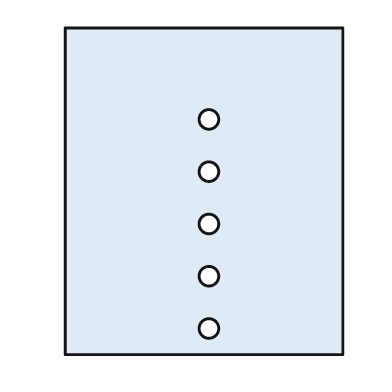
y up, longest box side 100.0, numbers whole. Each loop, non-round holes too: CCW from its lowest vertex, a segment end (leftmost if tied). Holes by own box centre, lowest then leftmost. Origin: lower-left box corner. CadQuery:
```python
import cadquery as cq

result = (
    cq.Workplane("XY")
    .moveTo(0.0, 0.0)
    .lineTo(85.0, 0.0)
    .lineTo(85.0, 100.0)
    .lineTo(0.0, 100.0)
    .close()
    .moveTo(44.0, 8.0)
    .circle(3.0)
    .moveTo(44.0, 24.0)
    .circle(3.0)
    .moveTo(44.0, 40.0)
    .circle(3.0)
    .moveTo(44.0, 56.0)
    .circle(3.0)
    .moveTo(44.0, 72.0)
    .circle(3.0)
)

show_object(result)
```